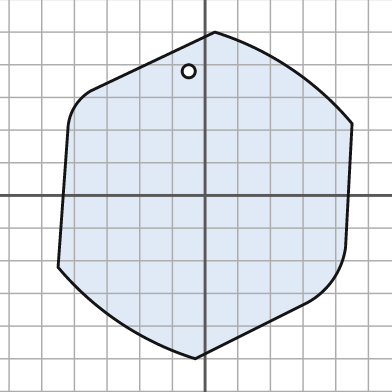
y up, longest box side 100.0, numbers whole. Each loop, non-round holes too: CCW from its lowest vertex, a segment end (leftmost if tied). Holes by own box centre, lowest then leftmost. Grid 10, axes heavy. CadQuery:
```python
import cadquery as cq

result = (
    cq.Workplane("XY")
    .moveTo(-3.0, -50.0)
    .lineTo(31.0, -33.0)
    .threePointArc((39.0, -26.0), (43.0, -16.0))
    .lineTo(45.0, 22.0)
    .threePointArc((26.0, 39.0), (3.0, 50.0))
    .lineTo(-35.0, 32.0)
    .threePointArc((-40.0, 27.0), (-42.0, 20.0))
    .lineTo(-45.0, -22.0)
    .threePointArc((-26.0, -39.0), (-3.0, -50.0))
    .close()
    .moveTo(-5.0, 38.0)
    .circle(2.0)
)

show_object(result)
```